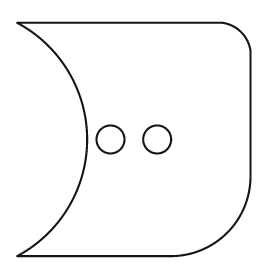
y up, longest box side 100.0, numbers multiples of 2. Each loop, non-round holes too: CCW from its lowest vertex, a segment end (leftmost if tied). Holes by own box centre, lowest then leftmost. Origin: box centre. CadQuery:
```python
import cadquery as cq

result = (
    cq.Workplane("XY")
    .moveTo(-50.0, -50.0)
    .lineTo(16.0, -50.0)
    .threePointArc((40.0, -40.0), (50.0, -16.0))
    .lineTo(50.0, 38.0)
    .threePointArc((46.0, 46.0), (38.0, 50.0))
    .lineTo(-50.0, 50.0)
    .threePointArc((-20.0, 0.0), (-50.0, -50.0))
    .close()
    .moveTo(-10.0, 0.0)
    .circle(6.0)
    .moveTo(10.0, 0.0)
    .circle(6.0)
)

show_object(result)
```